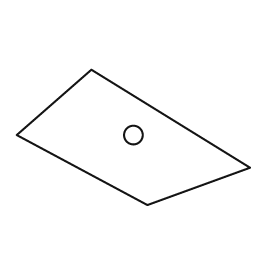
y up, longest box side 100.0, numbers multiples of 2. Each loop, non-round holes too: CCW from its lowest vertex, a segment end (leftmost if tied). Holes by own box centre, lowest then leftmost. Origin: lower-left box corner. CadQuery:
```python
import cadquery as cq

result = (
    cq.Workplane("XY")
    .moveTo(56.0, 0.0)
    .lineTo(100.0, 16.0)
    .lineTo(32.0, 58.0)
    .lineTo(0.0, 30.0)
    .close()
    .moveTo(50.0, 30.0)
    .circle(4.0)
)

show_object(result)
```